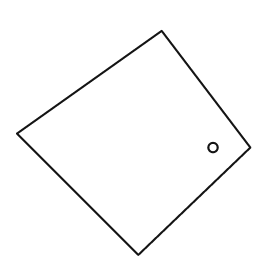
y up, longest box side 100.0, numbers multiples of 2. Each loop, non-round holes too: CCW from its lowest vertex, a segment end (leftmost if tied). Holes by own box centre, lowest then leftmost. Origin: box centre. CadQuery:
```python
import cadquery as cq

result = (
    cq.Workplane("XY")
    .moveTo(2.0, -48.0)
    .lineTo(50.0, -2.0)
    .lineTo(12.0, 48.0)
    .lineTo(-50.0, 4.0)
    .close()
    .moveTo(34.0, -2.0)
    .circle(2.0)
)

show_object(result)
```